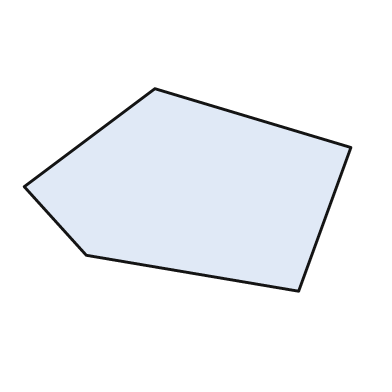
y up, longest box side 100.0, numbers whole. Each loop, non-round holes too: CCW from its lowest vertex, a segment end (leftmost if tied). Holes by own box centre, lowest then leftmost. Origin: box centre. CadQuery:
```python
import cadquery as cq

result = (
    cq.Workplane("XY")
    .moveTo(34.0, -31.0)
    .lineTo(50.0, 13.0)
    .lineTo(-10.0, 31.0)
    .lineTo(-50.0, 1.0)
    .lineTo(-31.0, -20.0)
    .close()
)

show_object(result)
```